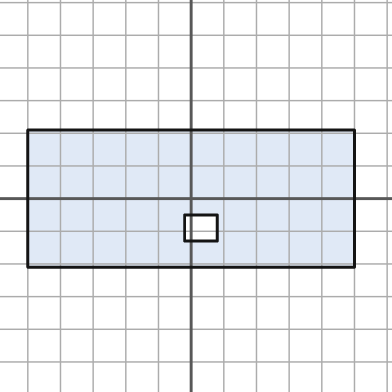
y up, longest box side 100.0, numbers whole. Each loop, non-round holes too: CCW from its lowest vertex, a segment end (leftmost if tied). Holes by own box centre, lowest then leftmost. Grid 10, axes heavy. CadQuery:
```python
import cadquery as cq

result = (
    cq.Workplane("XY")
    .moveTo(-50.0, -21.0)
    .lineTo(50.0, -21.0)
    .lineTo(50.0, 21.0)
    .lineTo(-50.0, 21.0)
    .close()
    .moveTo(-2.0, -13.0)
    .lineTo(8.0, -13.0)
    .lineTo(8.0, -5.0)
    .lineTo(-2.0, -5.0)
    .close()
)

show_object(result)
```